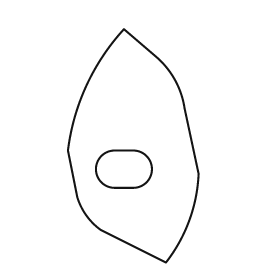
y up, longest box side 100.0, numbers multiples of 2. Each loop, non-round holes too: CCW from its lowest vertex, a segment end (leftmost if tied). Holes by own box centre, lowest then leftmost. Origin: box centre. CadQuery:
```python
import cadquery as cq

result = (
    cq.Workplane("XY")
    .moveTo(14.0, -50.0)
    .threePointArc((24.0, -32.0), (28.0, -12.0))
    .lineTo(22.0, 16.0)
    .threePointArc((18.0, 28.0), (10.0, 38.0))
    .lineTo(-4.0, 50.0)
    .threePointArc((-20.0, 26.0), (-28.0, -2.0))
    .lineTo(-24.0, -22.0)
    .threePointArc((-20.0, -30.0), (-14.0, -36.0))
    .close()
    .moveTo(-8.0, -18.0)
    .lineTo(0.0, -18.0)
    .threePointArc((8.0, -10.0), (0.0, -2.0))
    .lineTo(-8.0, -2.0)
    .threePointArc((-16.0, -10.0), (-8.0, -18.0))
    .close()
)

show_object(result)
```